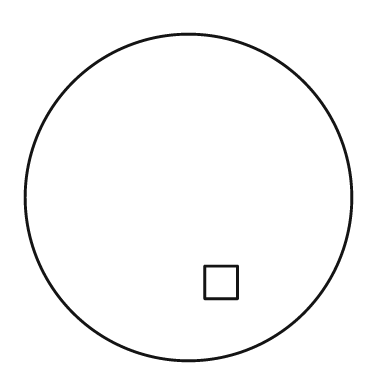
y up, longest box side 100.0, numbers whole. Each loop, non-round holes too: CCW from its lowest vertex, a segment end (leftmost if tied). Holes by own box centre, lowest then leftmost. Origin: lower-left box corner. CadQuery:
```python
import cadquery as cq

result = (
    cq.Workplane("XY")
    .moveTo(50.0, 50.0)
    .circle(50.0)
    .moveTo(55.0, 19.0)
    .lineTo(65.0, 19.0)
    .lineTo(65.0, 29.0)
    .lineTo(55.0, 29.0)
    .close()
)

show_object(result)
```